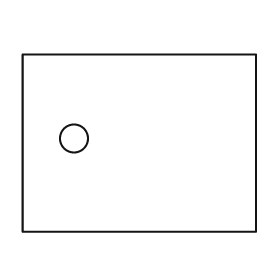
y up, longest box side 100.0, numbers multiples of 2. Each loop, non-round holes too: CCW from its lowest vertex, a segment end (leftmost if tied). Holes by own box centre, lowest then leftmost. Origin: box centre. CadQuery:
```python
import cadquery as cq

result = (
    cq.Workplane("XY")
    .moveTo(-50.0, -38.0)
    .lineTo(50.0, -38.0)
    .lineTo(50.0, 38.0)
    .lineTo(-50.0, 38.0)
    .close()
    .moveTo(-28.0, 2.0)
    .circle(6.0)
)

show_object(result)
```